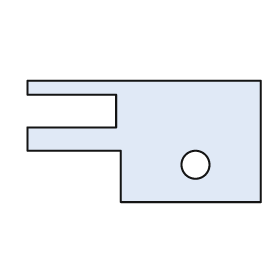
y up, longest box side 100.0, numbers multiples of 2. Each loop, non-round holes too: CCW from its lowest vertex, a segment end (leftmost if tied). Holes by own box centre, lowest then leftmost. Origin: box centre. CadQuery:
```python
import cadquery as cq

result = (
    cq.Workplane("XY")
    .moveTo(-10.0, -26.0)
    .lineTo(50.0, -26.0)
    .lineTo(50.0, 26.0)
    .lineTo(-50.0, 26.0)
    .lineTo(-50.0, 20.0)
    .lineTo(-12.0, 20.0)
    .lineTo(-12.0, 6.0)
    .lineTo(-50.0, 6.0)
    .lineTo(-50.0, -4.0)
    .lineTo(-10.0, -4.0)
    .close()
    .moveTo(22.0, -10.0)
    .circle(6.0)
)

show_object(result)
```